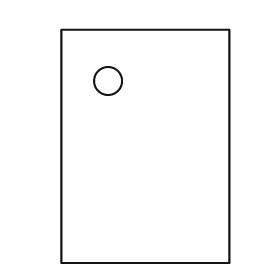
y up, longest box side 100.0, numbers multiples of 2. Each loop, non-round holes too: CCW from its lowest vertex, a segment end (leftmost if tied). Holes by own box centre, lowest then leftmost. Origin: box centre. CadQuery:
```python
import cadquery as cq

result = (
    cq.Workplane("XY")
    .moveTo(-36.0, -50.0)
    .lineTo(36.0, -50.0)
    .lineTo(36.0, 50.0)
    .lineTo(-36.0, 50.0)
    .close()
    .moveTo(-16.0, 28.0)
    .circle(6.0)
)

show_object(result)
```